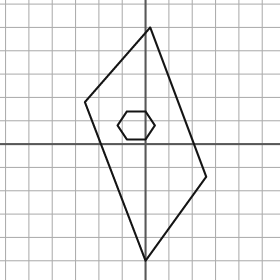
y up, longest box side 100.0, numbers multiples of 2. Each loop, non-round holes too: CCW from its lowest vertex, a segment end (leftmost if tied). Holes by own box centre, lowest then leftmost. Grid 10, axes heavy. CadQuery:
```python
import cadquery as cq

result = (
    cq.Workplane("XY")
    .moveTo(0.0, -50.0)
    .lineTo(26.0, -14.0)
    .lineTo(2.0, 50.0)
    .lineTo(-26.0, 18.0)
    .close()
    .moveTo(-8.0, 2.0)
    .lineTo(0.0, 2.0)
    .lineTo(4.0, 8.0)
    .lineTo(0.0, 14.0)
    .lineTo(-8.0, 14.0)
    .lineTo(-12.0, 8.0)
    .close()
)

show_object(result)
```